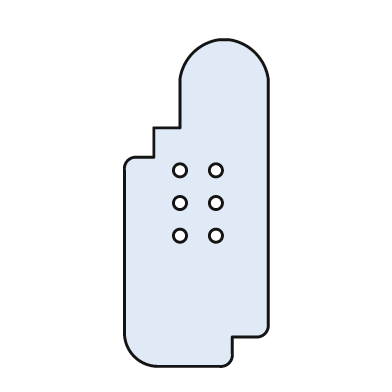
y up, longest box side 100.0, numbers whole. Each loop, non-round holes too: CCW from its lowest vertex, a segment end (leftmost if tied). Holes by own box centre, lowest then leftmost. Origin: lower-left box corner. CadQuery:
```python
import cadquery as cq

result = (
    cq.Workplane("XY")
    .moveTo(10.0, 0.0)
    .lineTo(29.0, 0.0)
    .threePointArc((32.0, 1.0), (33.0, 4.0))
    .lineTo(33.0, 9.0)
    .lineTo(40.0, 9.0)
    .threePointArc((43.0, 10.0), (44.0, 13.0))
    .lineTo(44.0, 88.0)
    .threePointArc((40.0, 96.0), (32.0, 100.0))
    .lineTo(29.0, 100.0)
    .threePointArc((21.0, 96.0), (17.0, 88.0))
    .lineTo(17.0, 73.0)
    .lineTo(9.0, 73.0)
    .lineTo(9.0, 64.0)
    .lineTo(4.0, 64.0)
    .threePointArc((1.0, 63.0), (0.0, 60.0))
    .lineTo(0.0, 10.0)
    .threePointArc((3.0, 3.0), (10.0, 0.0))
    .close()
    .moveTo(17.0, 40.0)
    .circle(2.0)
    .moveTo(28.0, 40.0)
    .circle(2.0)
    .moveTo(17.0, 50.0)
    .circle(2.0)
    .moveTo(28.0, 50.0)
    .circle(2.0)
    .moveTo(17.0, 60.0)
    .circle(2.0)
    .moveTo(28.0, 60.0)
    .circle(2.0)
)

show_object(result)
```